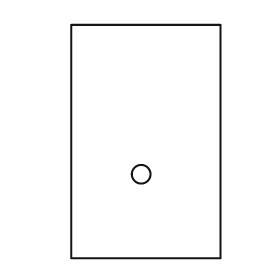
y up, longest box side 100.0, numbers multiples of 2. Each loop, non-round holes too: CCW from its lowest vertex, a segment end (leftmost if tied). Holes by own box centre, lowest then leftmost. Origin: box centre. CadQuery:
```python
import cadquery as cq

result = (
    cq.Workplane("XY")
    .moveTo(-32.0, -50.0)
    .lineTo(32.0, -50.0)
    .lineTo(32.0, 50.0)
    .lineTo(-32.0, 50.0)
    .close()
    .moveTo(-2.0, -14.0)
    .circle(4.0)
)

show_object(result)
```